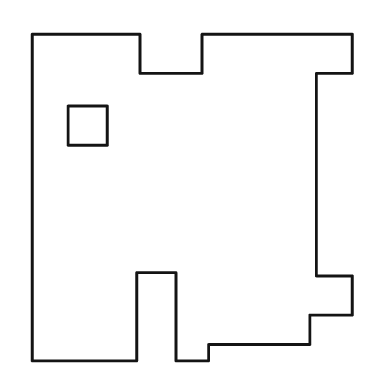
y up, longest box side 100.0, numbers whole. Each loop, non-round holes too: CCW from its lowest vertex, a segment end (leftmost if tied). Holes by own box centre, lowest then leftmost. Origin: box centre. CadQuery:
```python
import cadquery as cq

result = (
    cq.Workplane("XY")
    .moveTo(-49.0, -50.0)
    .lineTo(-17.0, -50.0)
    .lineTo(-17.0, -23.0)
    .lineTo(-5.0, -23.0)
    .lineTo(-5.0, -50.0)
    .lineTo(5.0, -50.0)
    .lineTo(5.0, -45.0)
    .lineTo(36.0, -45.0)
    .lineTo(36.0, -36.0)
    .lineTo(49.0, -36.0)
    .lineTo(49.0, -24.0)
    .lineTo(38.0, -24.0)
    .lineTo(38.0, 38.0)
    .lineTo(49.0, 38.0)
    .lineTo(49.0, 50.0)
    .lineTo(3.0, 50.0)
    .lineTo(3.0, 38.0)
    .lineTo(-16.0, 38.0)
    .lineTo(-16.0, 50.0)
    .lineTo(-49.0, 50.0)
    .close()
    .moveTo(-38.0, 16.0)
    .lineTo(-26.0, 16.0)
    .lineTo(-26.0, 28.0)
    .lineTo(-38.0, 28.0)
    .close()
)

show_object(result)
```